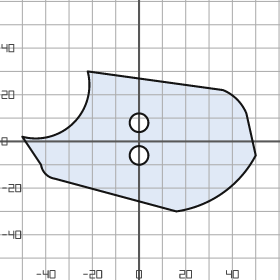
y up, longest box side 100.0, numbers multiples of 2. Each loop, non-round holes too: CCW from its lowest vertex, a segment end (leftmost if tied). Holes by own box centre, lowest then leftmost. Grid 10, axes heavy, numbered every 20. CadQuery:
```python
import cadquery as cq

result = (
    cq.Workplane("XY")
    .moveTo(16.0, -30.0)
    .threePointArc((36.0, -22.0), (50.0, -6.0))
    .lineTo(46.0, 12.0)
    .threePointArc((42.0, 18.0), (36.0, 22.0))
    .lineTo(-22.0, 30.0)
    .threePointArc((-28.0, 8.0), (-50.0, 2.0))
    .lineTo(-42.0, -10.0)
    .threePointArc((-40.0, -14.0), (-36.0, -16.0))
    .close()
    .moveTo(0.0, -6.0)
    .circle(4.0)
    .moveTo(0.0, 8.0)
    .circle(4.0)
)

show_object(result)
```